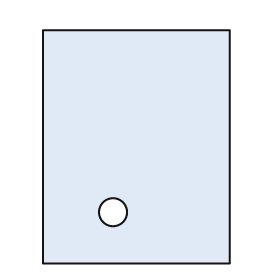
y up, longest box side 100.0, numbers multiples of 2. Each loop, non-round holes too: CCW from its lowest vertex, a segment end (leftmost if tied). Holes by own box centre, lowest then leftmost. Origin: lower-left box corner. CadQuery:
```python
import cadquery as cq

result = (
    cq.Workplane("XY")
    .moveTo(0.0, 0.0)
    .lineTo(80.0, 0.0)
    .lineTo(80.0, 100.0)
    .lineTo(0.0, 100.0)
    .close()
    .moveTo(30.0, 22.0)
    .circle(6.0)
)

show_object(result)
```